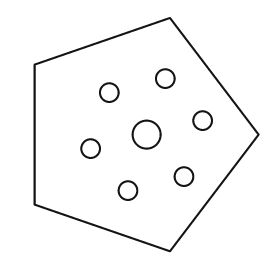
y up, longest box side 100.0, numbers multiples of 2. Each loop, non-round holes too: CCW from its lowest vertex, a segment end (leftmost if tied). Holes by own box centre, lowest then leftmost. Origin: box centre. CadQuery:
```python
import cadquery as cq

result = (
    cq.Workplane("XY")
    .moveTo(10.0, -50.0)
    .lineTo(48.0, 0.0)
    .lineTo(10.0, 50.0)
    .lineTo(-48.0, 30.0)
    .lineTo(-48.0, -30.0)
    .close()
    .moveTo(-8.0, -24.0)
    .circle(4.0)
    .moveTo(16.0, -18.0)
    .circle(4.0)
    .moveTo(-24.0, -6.0)
    .circle(4.0)
    .moveTo(0.0, 0.0)
    .circle(6.0)
    .moveTo(24.0, 6.0)
    .circle(4.0)
    .moveTo(-16.0, 18.0)
    .circle(4.0)
    .moveTo(8.0, 24.0)
    .circle(4.0)
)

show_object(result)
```